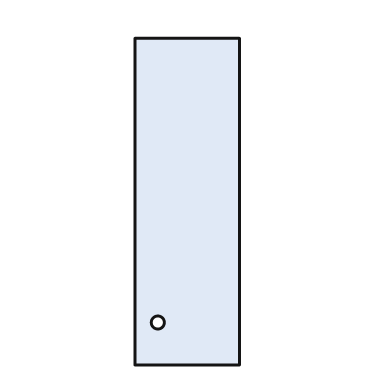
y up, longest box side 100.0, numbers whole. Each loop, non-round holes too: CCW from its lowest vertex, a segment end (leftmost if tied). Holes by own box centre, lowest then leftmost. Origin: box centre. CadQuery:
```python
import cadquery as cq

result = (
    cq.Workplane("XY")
    .moveTo(-16.0, -50.0)
    .lineTo(16.0, -50.0)
    .lineTo(16.0, 50.0)
    .lineTo(-16.0, 50.0)
    .close()
    .moveTo(-9.0, -37.0)
    .circle(2.0)
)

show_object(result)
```